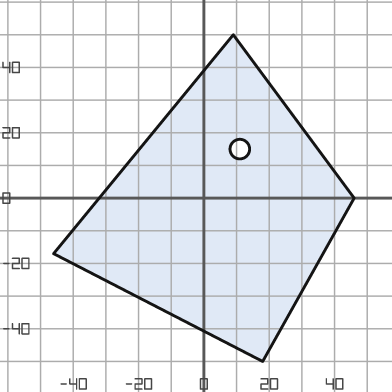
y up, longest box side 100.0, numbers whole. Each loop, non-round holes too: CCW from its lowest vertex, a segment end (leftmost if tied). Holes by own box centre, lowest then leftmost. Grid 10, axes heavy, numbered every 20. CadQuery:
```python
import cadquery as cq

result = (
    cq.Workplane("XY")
    .moveTo(18.0, -50.0)
    .lineTo(46.0, 0.0)
    .lineTo(9.0, 50.0)
    .lineTo(-46.0, -17.0)
    .close()
    .moveTo(11.0, 15.0)
    .circle(3.0)
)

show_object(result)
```